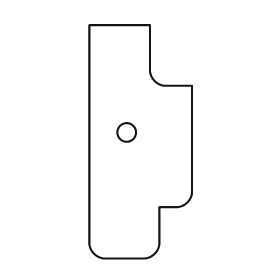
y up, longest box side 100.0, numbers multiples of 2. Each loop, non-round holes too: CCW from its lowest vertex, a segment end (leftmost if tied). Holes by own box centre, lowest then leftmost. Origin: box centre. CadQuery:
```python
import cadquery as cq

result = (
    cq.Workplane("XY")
    .moveTo(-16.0, -50.0)
    .lineTo(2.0, -50.0)
    .threePointArc((6.0, -48.0), (8.0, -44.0))
    .lineTo(8.0, -28.0)
    .lineTo(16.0, -28.0)
    .threePointArc((20.0, -26.0), (22.0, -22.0))
    .lineTo(22.0, 24.0)
    .lineTo(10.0, 24.0)
    .threePointArc((6.0, 26.0), (4.0, 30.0))
    .lineTo(4.0, 50.0)
    .lineTo(-22.0, 50.0)
    .lineTo(-22.0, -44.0)
    .threePointArc((-20.0, -48.0), (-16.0, -50.0))
    .close()
    .moveTo(-6.0, 4.0)
    .circle(4.0)
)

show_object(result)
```